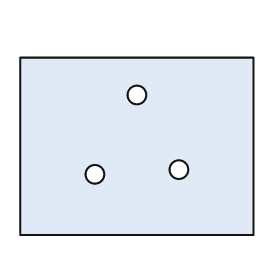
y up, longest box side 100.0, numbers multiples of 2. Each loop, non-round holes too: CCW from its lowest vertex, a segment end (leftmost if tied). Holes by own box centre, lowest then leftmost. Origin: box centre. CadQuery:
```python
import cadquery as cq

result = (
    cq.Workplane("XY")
    .moveTo(-50.0, -38.0)
    .lineTo(50.0, -38.0)
    .lineTo(50.0, 38.0)
    .lineTo(-50.0, 38.0)
    .close()
    .moveTo(-18.0, -12.0)
    .circle(4.0)
    .moveTo(18.0, -10.0)
    .circle(4.0)
    .moveTo(0.0, 22.0)
    .circle(4.0)
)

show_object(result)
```